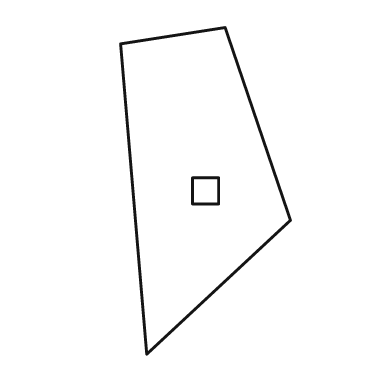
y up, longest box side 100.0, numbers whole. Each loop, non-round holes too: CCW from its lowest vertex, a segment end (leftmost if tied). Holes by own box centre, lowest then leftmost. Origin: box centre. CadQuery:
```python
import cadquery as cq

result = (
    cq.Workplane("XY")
    .moveTo(-18.0, -50.0)
    .lineTo(26.0, -9.0)
    .lineTo(6.0, 50.0)
    .lineTo(-26.0, 45.0)
    .close()
    .moveTo(-4.0, -4.0)
    .lineTo(4.0, -4.0)
    .lineTo(4.0, 4.0)
    .lineTo(-4.0, 4.0)
    .close()
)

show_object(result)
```